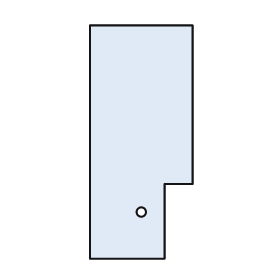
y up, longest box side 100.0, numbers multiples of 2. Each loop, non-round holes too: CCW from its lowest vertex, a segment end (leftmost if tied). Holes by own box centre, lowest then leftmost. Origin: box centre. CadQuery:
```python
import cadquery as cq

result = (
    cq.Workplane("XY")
    .moveTo(-22.0, -50.0)
    .lineTo(10.0, -50.0)
    .lineTo(10.0, -18.0)
    .lineTo(22.0, -18.0)
    .lineTo(22.0, 50.0)
    .lineTo(-22.0, 50.0)
    .close()
    .moveTo(0.0, -30.0)
    .circle(2.0)
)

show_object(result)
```